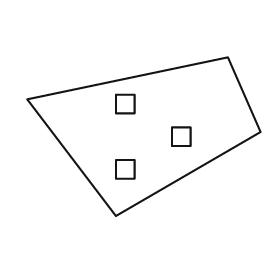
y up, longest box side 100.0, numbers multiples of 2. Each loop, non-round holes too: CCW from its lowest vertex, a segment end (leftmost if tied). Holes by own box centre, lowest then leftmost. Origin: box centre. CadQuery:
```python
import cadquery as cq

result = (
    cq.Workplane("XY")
    .moveTo(-12.0, -34.0)
    .lineTo(50.0, 2.0)
    .lineTo(36.0, 34.0)
    .lineTo(-50.0, 16.0)
    .close()
    .moveTo(-12.0, -18.0)
    .lineTo(-4.0, -18.0)
    .lineTo(-4.0, -10.0)
    .lineTo(-12.0, -10.0)
    .close()
    .moveTo(12.0, -4.0)
    .lineTo(20.0, -4.0)
    .lineTo(20.0, 4.0)
    .lineTo(12.0, 4.0)
    .close()
    .moveTo(-12.0, 10.0)
    .lineTo(-4.0, 10.0)
    .lineTo(-4.0, 18.0)
    .lineTo(-12.0, 18.0)
    .close()
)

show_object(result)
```